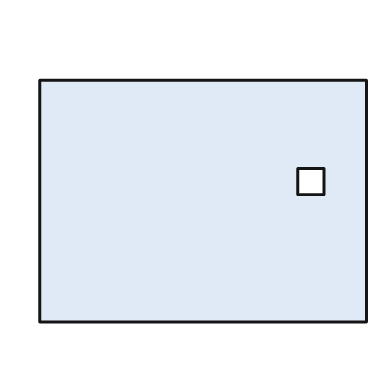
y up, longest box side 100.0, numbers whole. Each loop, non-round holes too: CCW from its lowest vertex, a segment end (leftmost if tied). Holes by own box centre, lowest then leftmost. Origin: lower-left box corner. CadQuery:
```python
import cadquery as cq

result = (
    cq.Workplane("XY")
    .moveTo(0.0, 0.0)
    .lineTo(100.0, 0.0)
    .lineTo(100.0, 74.0)
    .lineTo(0.0, 74.0)
    .close()
    .moveTo(79.0, 39.0)
    .lineTo(87.0, 39.0)
    .lineTo(87.0, 47.0)
    .lineTo(79.0, 47.0)
    .close()
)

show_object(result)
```